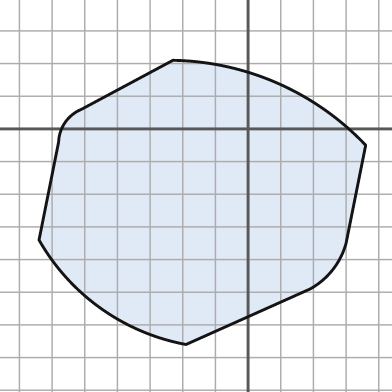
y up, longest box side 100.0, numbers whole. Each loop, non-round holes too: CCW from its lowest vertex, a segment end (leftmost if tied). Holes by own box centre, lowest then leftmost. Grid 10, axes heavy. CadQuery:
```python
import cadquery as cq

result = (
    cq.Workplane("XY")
    .moveTo(-19.0, -66.0)
    .lineTo(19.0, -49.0)
    .threePointArc((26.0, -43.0), (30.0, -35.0))
    .lineTo(36.0, -5.0)
    .threePointArc((9.0, 14.0), (-23.0, 21.0))
    .lineTo(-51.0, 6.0)
    .threePointArc((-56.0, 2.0), (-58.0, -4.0))
    .lineTo(-64.0, -34.0)
    .threePointArc((-45.0, -55.0), (-19.0, -66.0))
    .close()
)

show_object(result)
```